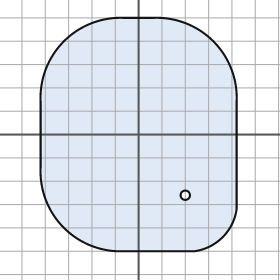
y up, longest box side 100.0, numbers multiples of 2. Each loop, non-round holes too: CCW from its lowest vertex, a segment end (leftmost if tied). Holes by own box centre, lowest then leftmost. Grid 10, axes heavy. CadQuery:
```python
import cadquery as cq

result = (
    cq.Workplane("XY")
    .moveTo(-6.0, -50.0)
    .lineTo(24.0, -50.0)
    .threePointArc((36.0, -44.0), (42.0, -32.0))
    .lineTo(42.0, 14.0)
    .threePointArc((32.0, 40.0), (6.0, 50.0))
    .lineTo(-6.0, 50.0)
    .threePointArc((-32.0, 40.0), (-42.0, 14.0))
    .lineTo(-42.0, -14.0)
    .threePointArc((-32.0, -40.0), (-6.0, -50.0))
    .close()
    .moveTo(20.0, -26.0)
    .circle(2.0)
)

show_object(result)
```